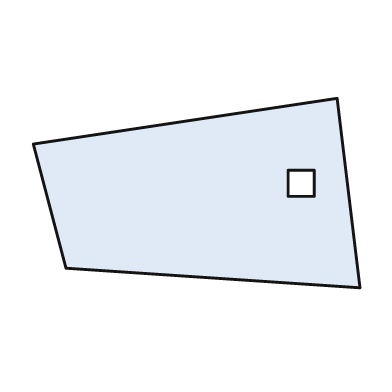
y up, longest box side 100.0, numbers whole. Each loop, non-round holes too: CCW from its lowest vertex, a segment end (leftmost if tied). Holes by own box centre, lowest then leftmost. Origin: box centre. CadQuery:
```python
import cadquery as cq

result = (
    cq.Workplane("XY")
    .moveTo(50.0, -29.0)
    .lineTo(43.0, 29.0)
    .lineTo(-50.0, 15.0)
    .lineTo(-40.0, -23.0)
    .close()
    .moveTo(28.0, -1.0)
    .lineTo(36.0, -1.0)
    .lineTo(36.0, 7.0)
    .lineTo(28.0, 7.0)
    .close()
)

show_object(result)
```